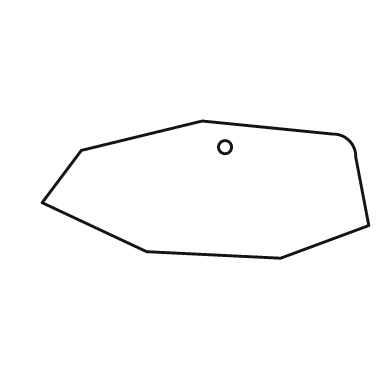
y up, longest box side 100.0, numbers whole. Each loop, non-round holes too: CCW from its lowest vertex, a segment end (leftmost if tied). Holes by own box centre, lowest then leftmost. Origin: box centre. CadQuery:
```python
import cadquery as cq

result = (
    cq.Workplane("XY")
    .moveTo(23.0, -21.0)
    .lineTo(50.0, -11.0)
    .lineTo(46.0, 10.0)
    .threePointArc((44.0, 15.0), (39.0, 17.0))
    .lineTo(-1.0, 21.0)
    .lineTo(-38.0, 12.0)
    .lineTo(-50.0, -4.0)
    .lineTo(-18.0, -19.0)
    .close()
    .moveTo(6.0, 13.0)
    .circle(2.0)
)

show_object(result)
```